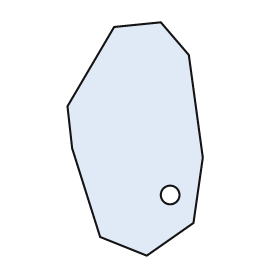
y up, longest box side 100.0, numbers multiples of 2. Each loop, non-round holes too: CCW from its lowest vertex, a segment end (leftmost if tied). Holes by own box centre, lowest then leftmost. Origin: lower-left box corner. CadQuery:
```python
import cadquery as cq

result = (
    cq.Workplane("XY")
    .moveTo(34.0, 0.0)
    .lineTo(54.0, 14.0)
    .lineTo(58.0, 42.0)
    .lineTo(52.0, 86.0)
    .lineTo(40.0, 100.0)
    .lineTo(20.0, 98.0)
    .lineTo(0.0, 64.0)
    .lineTo(2.0, 46.0)
    .lineTo(14.0, 8.0)
    .close()
    .moveTo(44.0, 26.0)
    .circle(4.0)
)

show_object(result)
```